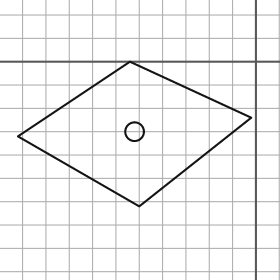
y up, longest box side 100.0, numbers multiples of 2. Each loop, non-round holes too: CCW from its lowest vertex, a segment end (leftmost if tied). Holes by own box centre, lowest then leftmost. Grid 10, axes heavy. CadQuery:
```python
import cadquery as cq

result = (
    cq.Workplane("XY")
    .moveTo(-50.0, -62.0)
    .lineTo(-2.0, -24.0)
    .lineTo(-54.0, 0.0)
    .lineTo(-102.0, -32.0)
    .close()
    .moveTo(-52.0, -30.0)
    .circle(4.0)
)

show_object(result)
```